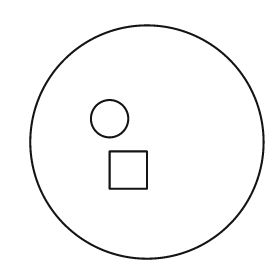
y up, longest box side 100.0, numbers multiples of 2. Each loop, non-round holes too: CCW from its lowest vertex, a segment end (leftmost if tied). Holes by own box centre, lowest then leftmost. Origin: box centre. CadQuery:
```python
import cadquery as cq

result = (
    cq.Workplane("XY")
    .moveTo(0.0, 0.0)
    .circle(50.0)
    .moveTo(-16.0, -20.0)
    .lineTo(0.0, -20.0)
    .lineTo(0.0, -4.0)
    .lineTo(-16.0, -4.0)
    .close()
    .moveTo(-16.0, 10.0)
    .circle(8.0)
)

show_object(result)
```